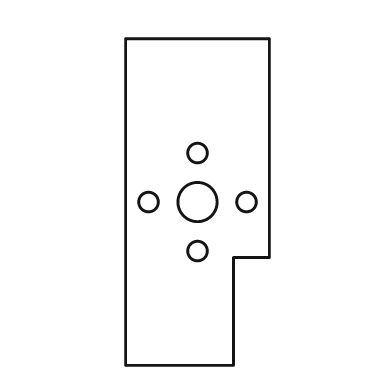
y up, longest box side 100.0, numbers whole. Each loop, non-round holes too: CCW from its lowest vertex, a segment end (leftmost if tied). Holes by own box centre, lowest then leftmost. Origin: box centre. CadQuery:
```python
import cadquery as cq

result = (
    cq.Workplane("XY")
    .moveTo(-22.0, -50.0)
    .lineTo(11.0, -50.0)
    .lineTo(11.0, -17.0)
    .lineTo(22.0, -17.0)
    .lineTo(22.0, 50.0)
    .lineTo(-22.0, 50.0)
    .close()
    .moveTo(0.0, -15.0)
    .circle(3.0)
    .moveTo(-15.0, 0.0)
    .circle(3.0)
    .moveTo(0.0, 0.0)
    .circle(6.0)
    .moveTo(15.0, 0.0)
    .circle(3.0)
    .moveTo(0.0, 15.0)
    .circle(3.0)
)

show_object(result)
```